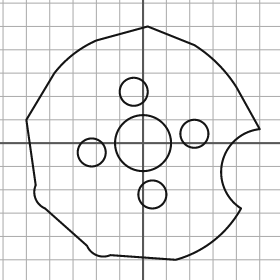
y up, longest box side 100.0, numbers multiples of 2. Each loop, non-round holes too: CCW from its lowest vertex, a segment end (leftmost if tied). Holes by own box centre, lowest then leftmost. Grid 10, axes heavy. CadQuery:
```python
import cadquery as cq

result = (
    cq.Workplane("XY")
    .moveTo(14.0, -50.0)
    .threePointArc((30.0, -42.0), (42.0, -28.0))
    .threePointArc((34.0, -8.0), (50.0, 6.0))
    .lineTo(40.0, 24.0)
    .threePointArc((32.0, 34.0), (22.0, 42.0))
    .lineTo(2.0, 50.0)
    .lineTo(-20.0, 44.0)
    .threePointArc((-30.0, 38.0), (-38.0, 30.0))
    .lineTo(-50.0, 10.0)
    .lineTo(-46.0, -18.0)
    .threePointArc((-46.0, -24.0), (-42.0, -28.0))
    .lineTo(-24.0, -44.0)
    .threePointArc((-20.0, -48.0), (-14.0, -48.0))
    .close()
    .moveTo(4.0, -22.0)
    .circle(6.0)
    .moveTo(-22.0, -4.0)
    .circle(6.0)
    .moveTo(0.0, 0.0)
    .circle(12.0)
    .moveTo(22.0, 4.0)
    .circle(6.0)
    .moveTo(-4.0, 22.0)
    .circle(6.0)
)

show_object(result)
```